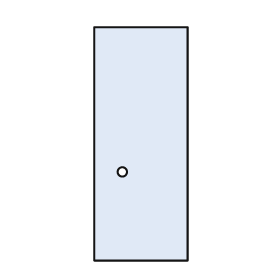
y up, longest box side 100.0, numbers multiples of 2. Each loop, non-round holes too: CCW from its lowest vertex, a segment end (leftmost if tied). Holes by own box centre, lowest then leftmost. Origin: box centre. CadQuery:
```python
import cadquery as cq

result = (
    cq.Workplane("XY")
    .moveTo(-20.0, -50.0)
    .lineTo(20.0, -50.0)
    .lineTo(20.0, 50.0)
    .lineTo(-20.0, 50.0)
    .close()
    .moveTo(-8.0, -12.0)
    .circle(2.0)
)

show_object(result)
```